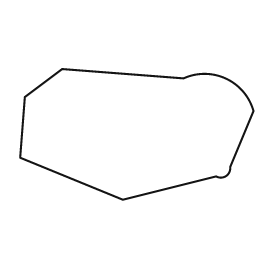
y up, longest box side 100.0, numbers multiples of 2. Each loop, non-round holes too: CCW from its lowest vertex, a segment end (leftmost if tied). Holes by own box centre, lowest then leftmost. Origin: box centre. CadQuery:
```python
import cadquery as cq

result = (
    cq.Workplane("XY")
    .moveTo(-6.0, -28.0)
    .lineTo(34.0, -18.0)
    .threePointArc((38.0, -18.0), (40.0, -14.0))
    .lineTo(50.0, 10.0)
    .threePointArc((38.0, 24.0), (20.0, 24.0))
    .lineTo(-32.0, 28.0)
    .lineTo(-48.0, 16.0)
    .lineTo(-50.0, -10.0)
    .close()
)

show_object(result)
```